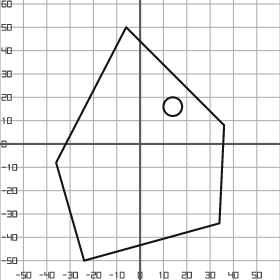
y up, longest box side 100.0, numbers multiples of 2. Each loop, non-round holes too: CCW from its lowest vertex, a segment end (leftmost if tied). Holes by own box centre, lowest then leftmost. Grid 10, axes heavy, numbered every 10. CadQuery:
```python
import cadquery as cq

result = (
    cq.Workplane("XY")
    .moveTo(-24.0, -50.0)
    .lineTo(34.0, -34.0)
    .lineTo(36.0, 8.0)
    .lineTo(-6.0, 50.0)
    .lineTo(-36.0, -8.0)
    .close()
    .moveTo(14.0, 16.0)
    .circle(4.0)
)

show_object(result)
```